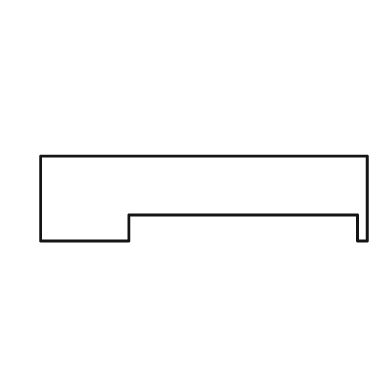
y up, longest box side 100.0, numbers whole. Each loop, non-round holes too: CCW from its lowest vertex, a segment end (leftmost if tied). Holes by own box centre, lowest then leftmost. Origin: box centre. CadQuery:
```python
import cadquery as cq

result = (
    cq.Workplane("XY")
    .moveTo(-50.0, -13.0)
    .lineTo(-23.0, -13.0)
    .lineTo(-23.0, -5.0)
    .lineTo(47.0, -5.0)
    .lineTo(47.0, -13.0)
    .lineTo(50.0, -13.0)
    .lineTo(50.0, 13.0)
    .lineTo(-50.0, 13.0)
    .close()
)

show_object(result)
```